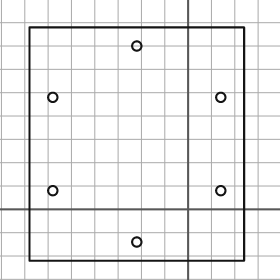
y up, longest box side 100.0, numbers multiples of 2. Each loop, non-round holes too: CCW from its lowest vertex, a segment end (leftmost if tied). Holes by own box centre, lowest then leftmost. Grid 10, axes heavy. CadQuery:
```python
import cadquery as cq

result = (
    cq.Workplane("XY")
    .moveTo(-68.0, -22.0)
    .lineTo(24.0, -22.0)
    .lineTo(24.0, 78.0)
    .lineTo(-68.0, 78.0)
    .close()
    .moveTo(-22.0, -14.0)
    .circle(2.0)
    .moveTo(-58.0, 8.0)
    .circle(2.0)
    .moveTo(14.0, 8.0)
    .circle(2.0)
    .moveTo(-58.0, 48.0)
    .circle(2.0)
    .moveTo(14.0, 48.0)
    .circle(2.0)
    .moveTo(-22.0, 70.0)
    .circle(2.0)
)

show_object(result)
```